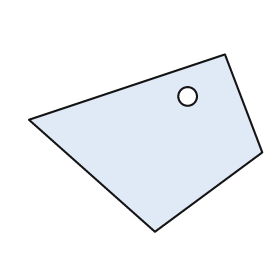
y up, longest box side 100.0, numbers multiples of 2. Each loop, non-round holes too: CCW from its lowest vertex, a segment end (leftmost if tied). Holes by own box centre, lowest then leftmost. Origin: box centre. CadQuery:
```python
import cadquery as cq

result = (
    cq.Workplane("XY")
    .moveTo(4.0, -38.0)
    .lineTo(50.0, -4.0)
    .lineTo(34.0, 38.0)
    .lineTo(-50.0, 10.0)
    .close()
    .moveTo(18.0, 20.0)
    .circle(4.0)
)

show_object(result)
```